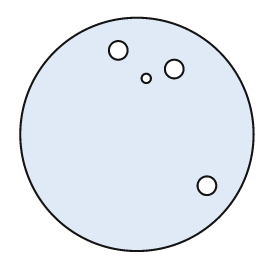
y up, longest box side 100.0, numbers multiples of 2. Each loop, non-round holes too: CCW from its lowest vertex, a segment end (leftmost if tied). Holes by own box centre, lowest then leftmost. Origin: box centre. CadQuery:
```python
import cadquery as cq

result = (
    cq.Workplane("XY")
    .moveTo(0.0, 0.0)
    .circle(50.0)
    .moveTo(30.0, -22.0)
    .circle(4.0)
    .moveTo(4.0, 24.0)
    .circle(2.0)
    .moveTo(16.0, 28.0)
    .circle(4.0)
    .moveTo(-8.0, 36.0)
    .circle(4.0)
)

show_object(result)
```